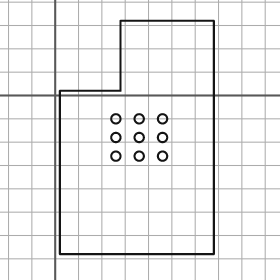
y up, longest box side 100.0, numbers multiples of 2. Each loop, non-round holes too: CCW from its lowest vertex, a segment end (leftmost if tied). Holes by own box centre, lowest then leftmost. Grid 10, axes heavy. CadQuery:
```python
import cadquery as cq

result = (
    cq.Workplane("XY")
    .moveTo(2.0, -68.0)
    .lineTo(68.0, -68.0)
    .lineTo(68.0, 32.0)
    .lineTo(28.0, 32.0)
    .lineTo(28.0, 2.0)
    .lineTo(2.0, 2.0)
    .close()
    .moveTo(26.0, -26.0)
    .circle(2.0)
    .moveTo(36.0, -26.0)
    .circle(2.0)
    .moveTo(46.0, -26.0)
    .circle(2.0)
    .moveTo(26.0, -18.0)
    .circle(2.0)
    .moveTo(36.0, -18.0)
    .circle(2.0)
    .moveTo(46.0, -18.0)
    .circle(2.0)
    .moveTo(26.0, -10.0)
    .circle(2.0)
    .moveTo(36.0, -10.0)
    .circle(2.0)
    .moveTo(46.0, -10.0)
    .circle(2.0)
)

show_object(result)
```